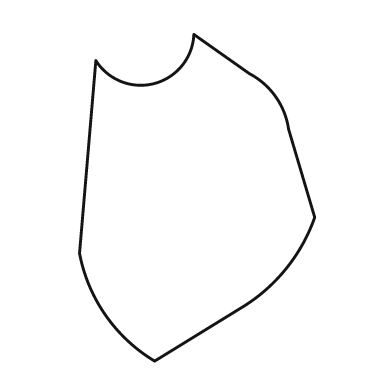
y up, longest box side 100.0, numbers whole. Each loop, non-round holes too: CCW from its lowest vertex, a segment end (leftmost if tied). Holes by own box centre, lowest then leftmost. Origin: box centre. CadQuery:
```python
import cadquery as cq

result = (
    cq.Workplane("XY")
    .moveTo(-13.0, -50.0)
    .lineTo(13.0, -34.0)
    .threePointArc((27.0, -22.0), (36.0, -6.0))
    .lineTo(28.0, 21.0)
    .threePointArc((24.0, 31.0), (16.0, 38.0))
    .lineTo(-1.0, 50.0)
    .threePointArc((-13.0, 35.0), (-31.0, 42.0))
    .lineTo(-36.0, -17.0)
    .threePointArc((-28.0, -36.0), (-13.0, -50.0))
    .close()
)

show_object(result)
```